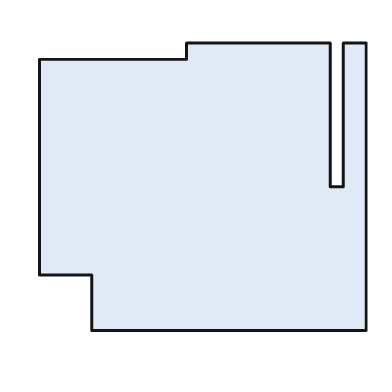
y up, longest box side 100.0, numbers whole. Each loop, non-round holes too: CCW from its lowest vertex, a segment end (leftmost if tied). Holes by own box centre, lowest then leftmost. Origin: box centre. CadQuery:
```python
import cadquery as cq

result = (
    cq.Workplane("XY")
    .moveTo(-34.0, -44.0)
    .lineTo(50.0, -44.0)
    .lineTo(50.0, 44.0)
    .lineTo(43.0, 44.0)
    .lineTo(43.0, 0.0)
    .lineTo(39.0, 0.0)
    .lineTo(39.0, 44.0)
    .lineTo(-5.0, 44.0)
    .lineTo(-5.0, 39.0)
    .lineTo(-50.0, 39.0)
    .lineTo(-50.0, -27.0)
    .lineTo(-34.0, -27.0)
    .close()
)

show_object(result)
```